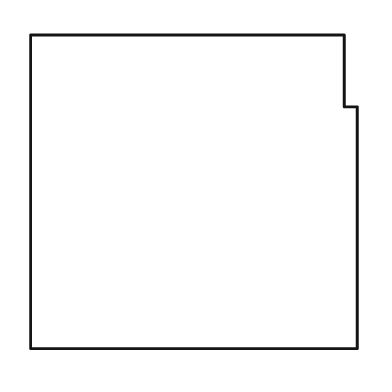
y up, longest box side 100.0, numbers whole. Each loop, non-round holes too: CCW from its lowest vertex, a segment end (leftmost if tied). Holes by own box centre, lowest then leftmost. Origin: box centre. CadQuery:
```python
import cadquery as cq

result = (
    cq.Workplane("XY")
    .moveTo(-50.0, -48.0)
    .lineTo(50.0, -48.0)
    .lineTo(50.0, 26.0)
    .lineTo(46.0, 26.0)
    .lineTo(46.0, 48.0)
    .lineTo(-50.0, 48.0)
    .close()
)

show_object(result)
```